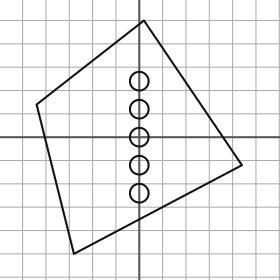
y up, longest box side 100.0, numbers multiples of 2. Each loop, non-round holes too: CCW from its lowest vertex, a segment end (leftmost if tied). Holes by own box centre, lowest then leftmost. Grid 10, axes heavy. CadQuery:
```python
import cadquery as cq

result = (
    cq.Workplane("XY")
    .moveTo(-28.0, -50.0)
    .lineTo(44.0, -12.0)
    .lineTo(2.0, 50.0)
    .lineTo(-44.0, 14.0)
    .close()
    .moveTo(0.0, -24.0)
    .circle(4.0)
    .moveTo(0.0, -12.0)
    .circle(4.0)
    .moveTo(0.0, 0.0)
    .circle(4.0)
    .moveTo(0.0, 12.0)
    .circle(4.0)
    .moveTo(0.0, 24.0)
    .circle(4.0)
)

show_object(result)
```